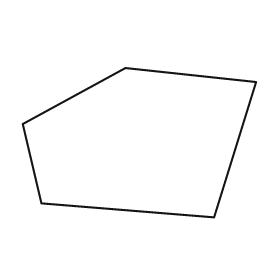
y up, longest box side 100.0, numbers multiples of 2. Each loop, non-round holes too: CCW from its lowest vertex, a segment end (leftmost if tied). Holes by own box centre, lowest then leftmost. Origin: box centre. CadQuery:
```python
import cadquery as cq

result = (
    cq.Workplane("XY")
    .moveTo(32.0, -32.0)
    .lineTo(50.0, 26.0)
    .lineTo(-6.0, 32.0)
    .lineTo(-50.0, 8.0)
    .lineTo(-42.0, -26.0)
    .close()
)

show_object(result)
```